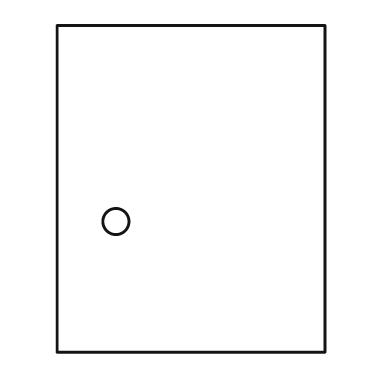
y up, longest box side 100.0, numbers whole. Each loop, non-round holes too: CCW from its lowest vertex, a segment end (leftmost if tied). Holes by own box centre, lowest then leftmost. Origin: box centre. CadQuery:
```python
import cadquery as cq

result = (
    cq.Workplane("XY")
    .moveTo(-41.0, -50.0)
    .lineTo(41.0, -50.0)
    .lineTo(41.0, 50.0)
    .lineTo(-41.0, 50.0)
    .close()
    .moveTo(-23.0, -10.0)
    .circle(4.0)
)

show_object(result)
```